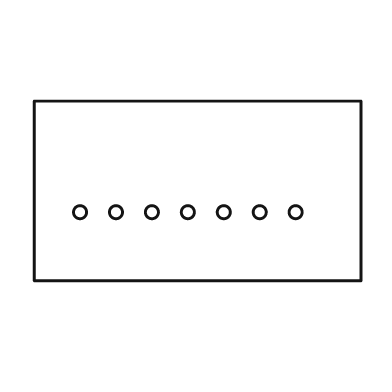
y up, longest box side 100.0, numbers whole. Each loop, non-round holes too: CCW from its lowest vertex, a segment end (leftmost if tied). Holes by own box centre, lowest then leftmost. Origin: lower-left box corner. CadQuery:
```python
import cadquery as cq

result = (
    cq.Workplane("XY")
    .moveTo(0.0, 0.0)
    .lineTo(100.0, 0.0)
    .lineTo(100.0, 55.0)
    .lineTo(0.0, 55.0)
    .close()
    .moveTo(14.0, 21.0)
    .circle(2.0)
    .moveTo(25.0, 21.0)
    .circle(2.0)
    .moveTo(36.0, 21.0)
    .circle(2.0)
    .moveTo(47.0, 21.0)
    .circle(2.0)
    .moveTo(58.0, 21.0)
    .circle(2.0)
    .moveTo(69.0, 21.0)
    .circle(2.0)
    .moveTo(80.0, 21.0)
    .circle(2.0)
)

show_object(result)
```